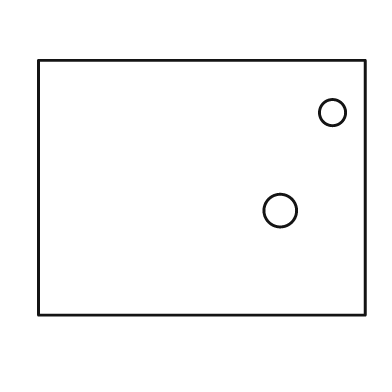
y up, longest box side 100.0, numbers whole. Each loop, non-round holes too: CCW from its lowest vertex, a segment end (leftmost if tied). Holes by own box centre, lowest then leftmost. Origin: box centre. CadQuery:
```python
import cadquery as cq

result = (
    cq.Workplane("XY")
    .moveTo(-50.0, -39.0)
    .lineTo(50.0, -39.0)
    .lineTo(50.0, 39.0)
    .lineTo(-50.0, 39.0)
    .close()
    .moveTo(24.0, -7.0)
    .circle(5.0)
    .moveTo(40.0, 23.0)
    .circle(4.0)
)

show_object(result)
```